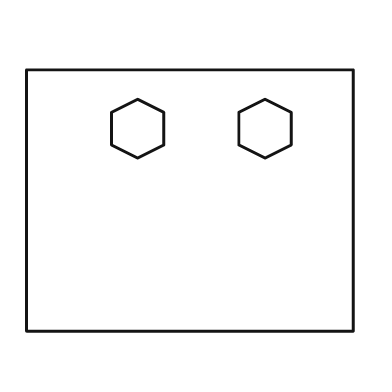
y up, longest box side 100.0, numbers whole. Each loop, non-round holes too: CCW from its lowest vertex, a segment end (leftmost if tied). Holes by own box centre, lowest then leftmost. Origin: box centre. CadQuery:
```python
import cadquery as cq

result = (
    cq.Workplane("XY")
    .moveTo(-50.0, -40.0)
    .lineTo(50.0, -40.0)
    .lineTo(50.0, 40.0)
    .lineTo(-50.0, 40.0)
    .close()
    .moveTo(-16.0, 13.0)
    .lineTo(-8.0, 17.0)
    .lineTo(-8.0, 27.0)
    .lineTo(-16.0, 31.0)
    .lineTo(-24.0, 27.0)
    .lineTo(-24.0, 17.0)
    .close()
    .moveTo(23.0, 13.0)
    .lineTo(31.0, 17.0)
    .lineTo(31.0, 27.0)
    .lineTo(23.0, 31.0)
    .lineTo(15.0, 27.0)
    .lineTo(15.0, 17.0)
    .close()
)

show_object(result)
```